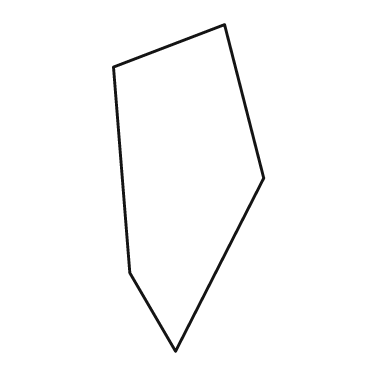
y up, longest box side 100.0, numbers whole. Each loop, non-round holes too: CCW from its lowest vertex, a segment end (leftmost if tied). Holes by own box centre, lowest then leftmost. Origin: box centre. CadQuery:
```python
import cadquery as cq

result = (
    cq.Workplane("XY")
    .moveTo(-4.0, -50.0)
    .lineTo(23.0, 3.0)
    .lineTo(11.0, 50.0)
    .lineTo(-23.0, 37.0)
    .lineTo(-18.0, -26.0)
    .close()
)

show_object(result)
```